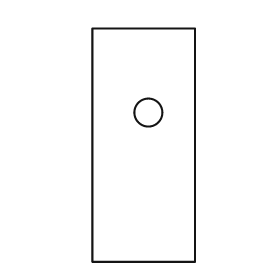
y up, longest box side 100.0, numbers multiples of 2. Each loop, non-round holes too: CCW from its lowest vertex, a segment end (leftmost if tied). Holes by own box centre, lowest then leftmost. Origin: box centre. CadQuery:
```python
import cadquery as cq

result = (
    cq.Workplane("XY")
    .moveTo(-22.0, -50.0)
    .lineTo(22.0, -50.0)
    .lineTo(22.0, 50.0)
    .lineTo(-22.0, 50.0)
    .close()
    .moveTo(2.0, 14.0)
    .circle(6.0)
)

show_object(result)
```